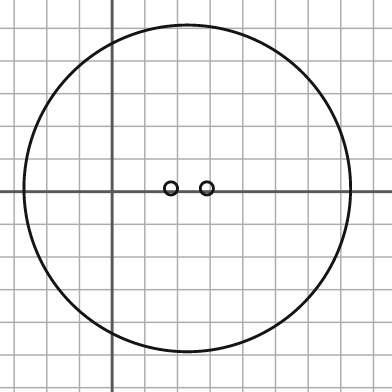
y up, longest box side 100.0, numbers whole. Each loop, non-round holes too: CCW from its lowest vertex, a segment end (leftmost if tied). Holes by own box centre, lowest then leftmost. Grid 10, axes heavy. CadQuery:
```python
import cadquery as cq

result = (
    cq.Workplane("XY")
    .moveTo(23.0, 1.0)
    .circle(50.0)
    .moveTo(18.0, 1.0)
    .circle(2.0)
    .moveTo(29.0, 1.0)
    .circle(2.0)
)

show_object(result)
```